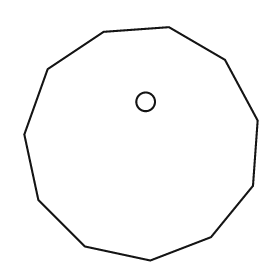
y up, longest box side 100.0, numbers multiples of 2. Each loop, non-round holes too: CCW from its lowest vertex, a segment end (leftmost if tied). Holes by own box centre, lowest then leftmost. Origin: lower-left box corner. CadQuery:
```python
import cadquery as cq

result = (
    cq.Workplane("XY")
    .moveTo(54.0, 0.0)
    .lineTo(80.0, 10.0)
    .lineTo(98.0, 32.0)
    .lineTo(100.0, 60.0)
    .lineTo(86.0, 86.0)
    .lineTo(62.0, 100.0)
    .lineTo(34.0, 98.0)
    .lineTo(10.0, 82.0)
    .lineTo(0.0, 54.0)
    .lineTo(6.0, 26.0)
    .lineTo(26.0, 6.0)
    .close()
    .moveTo(52.0, 68.0)
    .circle(4.0)
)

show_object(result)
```